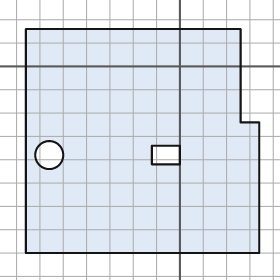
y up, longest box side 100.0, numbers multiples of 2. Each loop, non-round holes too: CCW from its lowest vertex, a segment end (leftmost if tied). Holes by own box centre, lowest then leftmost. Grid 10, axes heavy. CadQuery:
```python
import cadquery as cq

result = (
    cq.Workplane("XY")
    .moveTo(-66.0, -80.0)
    .lineTo(34.0, -80.0)
    .lineTo(34.0, -24.0)
    .lineTo(26.0, -24.0)
    .lineTo(26.0, 16.0)
    .lineTo(-66.0, 16.0)
    .close()
    .moveTo(-56.0, -38.0)
    .circle(6.0)
    .moveTo(-12.0, -42.0)
    .lineTo(0.0, -42.0)
    .lineTo(0.0, -34.0)
    .lineTo(-12.0, -34.0)
    .close()
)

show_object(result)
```